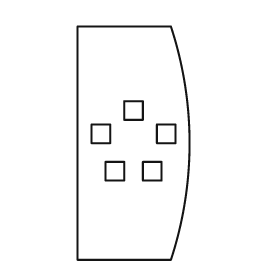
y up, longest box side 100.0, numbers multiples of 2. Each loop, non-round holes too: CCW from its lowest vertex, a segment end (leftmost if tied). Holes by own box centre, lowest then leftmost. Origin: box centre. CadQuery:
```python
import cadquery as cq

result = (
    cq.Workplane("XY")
    .moveTo(-24.0, -50.0)
    .lineTo(16.0, -50.0)
    .threePointArc((24.0, 0.0), (16.0, 50.0))
    .lineTo(-24.0, 50.0)
    .close()
    .moveTo(-12.0, -16.0)
    .lineTo(-4.0, -16.0)
    .lineTo(-4.0, -8.0)
    .lineTo(-12.0, -8.0)
    .close()
    .moveTo(4.0, -16.0)
    .lineTo(12.0, -16.0)
    .lineTo(12.0, -8.0)
    .lineTo(4.0, -8.0)
    .close()
    .moveTo(-18.0, 0.0)
    .lineTo(-10.0, 0.0)
    .lineTo(-10.0, 8.0)
    .lineTo(-18.0, 8.0)
    .close()
    .moveTo(10.0, 0.0)
    .lineTo(18.0, 0.0)
    .lineTo(18.0, 8.0)
    .lineTo(10.0, 8.0)
    .close()
    .moveTo(-4.0, 10.0)
    .lineTo(4.0, 10.0)
    .lineTo(4.0, 18.0)
    .lineTo(-4.0, 18.0)
    .close()
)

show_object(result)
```